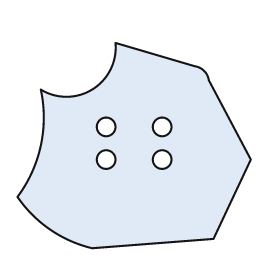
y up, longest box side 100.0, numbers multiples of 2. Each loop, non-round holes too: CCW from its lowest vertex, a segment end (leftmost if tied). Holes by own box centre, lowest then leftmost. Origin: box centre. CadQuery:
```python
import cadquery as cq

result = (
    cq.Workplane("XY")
    .moveTo(-18.0, -44.0)
    .lineTo(34.0, -40.0)
    .lineTo(50.0, -6.0)
    .lineTo(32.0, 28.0)
    .threePointArc((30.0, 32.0), (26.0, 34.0))
    .lineTo(-8.0, 44.0)
    .threePointArc((-18.0, 24.0), (-40.0, 24.0))
    .threePointArc((-40.0, 0.0), (-50.0, -22.0))
    .threePointArc((-36.0, -36.0), (-18.0, -44.0))
    .close()
    .moveTo(-12.0, -6.0)
    .circle(4.0)
    .moveTo(12.0, -6.0)
    .circle(4.0)
    .moveTo(-12.0, 8.0)
    .circle(4.0)
    .moveTo(12.0, 8.0)
    .circle(4.0)
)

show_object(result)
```